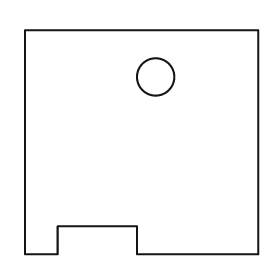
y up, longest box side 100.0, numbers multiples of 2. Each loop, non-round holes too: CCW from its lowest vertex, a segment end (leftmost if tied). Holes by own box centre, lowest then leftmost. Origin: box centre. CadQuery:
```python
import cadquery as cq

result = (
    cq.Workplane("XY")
    .moveTo(-50.0, -48.0)
    .lineTo(-36.0, -48.0)
    .lineTo(-36.0, -36.0)
    .lineTo(-2.0, -36.0)
    .lineTo(-2.0, -48.0)
    .lineTo(50.0, -48.0)
    .lineTo(50.0, 48.0)
    .lineTo(-50.0, 48.0)
    .close()
    .moveTo(6.0, 28.0)
    .circle(8.0)
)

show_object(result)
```